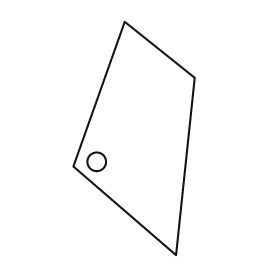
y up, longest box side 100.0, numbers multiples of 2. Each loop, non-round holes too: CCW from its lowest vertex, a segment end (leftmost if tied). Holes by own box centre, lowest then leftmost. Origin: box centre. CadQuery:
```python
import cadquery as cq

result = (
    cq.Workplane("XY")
    .moveTo(18.0, -50.0)
    .lineTo(26.0, 26.0)
    .lineTo(-4.0, 50.0)
    .lineTo(-26.0, -12.0)
    .close()
    .moveTo(-16.0, -10.0)
    .circle(4.0)
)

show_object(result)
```